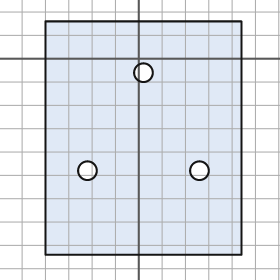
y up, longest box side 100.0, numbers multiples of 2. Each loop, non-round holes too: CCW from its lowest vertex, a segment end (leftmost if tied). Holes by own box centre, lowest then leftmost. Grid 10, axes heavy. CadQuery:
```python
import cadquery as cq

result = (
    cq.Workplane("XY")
    .moveTo(-40.0, -84.0)
    .lineTo(44.0, -84.0)
    .lineTo(44.0, 16.0)
    .lineTo(-40.0, 16.0)
    .close()
    .moveTo(-22.0, -48.0)
    .circle(4.0)
    .moveTo(26.0, -48.0)
    .circle(4.0)
    .moveTo(2.0, -6.0)
    .circle(4.0)
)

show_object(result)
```